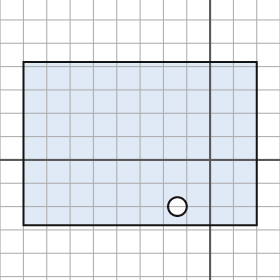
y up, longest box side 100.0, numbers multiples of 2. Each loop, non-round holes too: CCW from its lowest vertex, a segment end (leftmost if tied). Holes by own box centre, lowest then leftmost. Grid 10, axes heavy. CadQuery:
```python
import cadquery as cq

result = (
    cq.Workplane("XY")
    .moveTo(-80.0, -28.0)
    .lineTo(20.0, -28.0)
    .lineTo(20.0, 42.0)
    .lineTo(-80.0, 42.0)
    .close()
    .moveTo(-14.0, -20.0)
    .circle(4.0)
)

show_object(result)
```